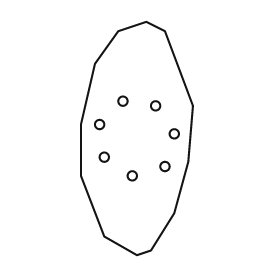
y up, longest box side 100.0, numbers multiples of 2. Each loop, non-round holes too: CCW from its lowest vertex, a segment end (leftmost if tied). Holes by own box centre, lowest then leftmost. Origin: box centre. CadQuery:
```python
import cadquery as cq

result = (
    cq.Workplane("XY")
    .moveTo(0.0, -50.0)
    .lineTo(6.0, -48.0)
    .lineTo(16.0, -32.0)
    .lineTo(22.0, -10.0)
    .lineTo(24.0, 14.0)
    .lineTo(12.0, 46.0)
    .lineTo(4.0, 50.0)
    .lineTo(-8.0, 46.0)
    .lineTo(-18.0, 32.0)
    .lineTo(-24.0, 6.0)
    .lineTo(-24.0, -16.0)
    .lineTo(-14.0, -42.0)
    .close()
    .moveTo(-2.0, -16.0)
    .circle(2.0)
    .moveTo(12.0, -12.0)
    .circle(2.0)
    .moveTo(-14.0, -8.0)
    .circle(2.0)
    .moveTo(16.0, 2.0)
    .circle(2.0)
    .moveTo(-16.0, 6.0)
    .circle(2.0)
    .moveTo(8.0, 14.0)
    .circle(2.0)
    .moveTo(-6.0, 16.0)
    .circle(2.0)
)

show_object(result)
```